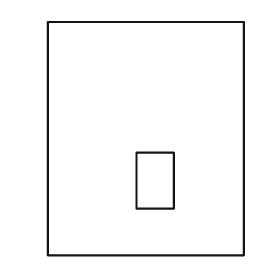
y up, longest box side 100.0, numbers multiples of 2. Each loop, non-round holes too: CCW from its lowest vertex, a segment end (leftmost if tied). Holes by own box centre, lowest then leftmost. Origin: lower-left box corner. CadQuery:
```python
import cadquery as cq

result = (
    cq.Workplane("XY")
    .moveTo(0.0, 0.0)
    .lineTo(84.0, 0.0)
    .lineTo(84.0, 100.0)
    .lineTo(0.0, 100.0)
    .close()
    .moveTo(38.0, 20.0)
    .lineTo(54.0, 20.0)
    .lineTo(54.0, 44.0)
    .lineTo(38.0, 44.0)
    .close()
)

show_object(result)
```